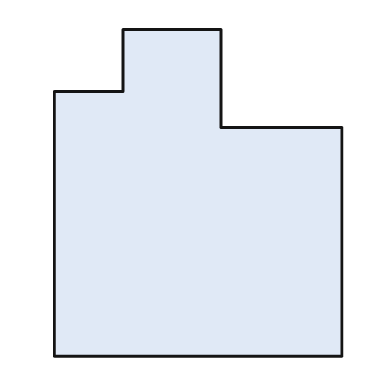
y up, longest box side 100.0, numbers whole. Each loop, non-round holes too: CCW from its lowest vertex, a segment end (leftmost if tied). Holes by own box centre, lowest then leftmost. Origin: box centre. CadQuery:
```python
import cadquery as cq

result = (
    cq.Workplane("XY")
    .moveTo(-44.0, -50.0)
    .lineTo(44.0, -50.0)
    .lineTo(44.0, 20.0)
    .lineTo(7.0, 20.0)
    .lineTo(7.0, 50.0)
    .lineTo(-23.0, 50.0)
    .lineTo(-23.0, 31.0)
    .lineTo(-44.0, 31.0)
    .close()
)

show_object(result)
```